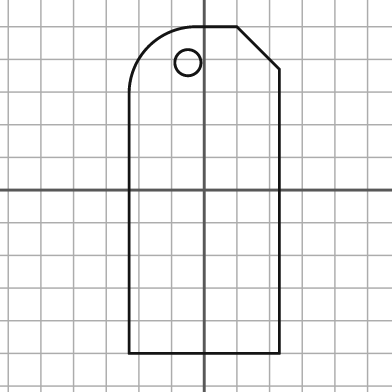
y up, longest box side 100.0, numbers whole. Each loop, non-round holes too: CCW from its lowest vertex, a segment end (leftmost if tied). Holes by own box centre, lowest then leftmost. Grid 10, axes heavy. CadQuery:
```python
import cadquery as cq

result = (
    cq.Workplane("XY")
    .moveTo(-23.0, -50.0)
    .lineTo(23.0, -50.0)
    .lineTo(23.0, 37.0)
    .lineTo(10.0, 50.0)
    .lineTo(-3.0, 50.0)
    .threePointArc((-17.0, 44.0), (-23.0, 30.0))
    .close()
    .moveTo(-5.0, 39.0)
    .circle(4.0)
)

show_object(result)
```